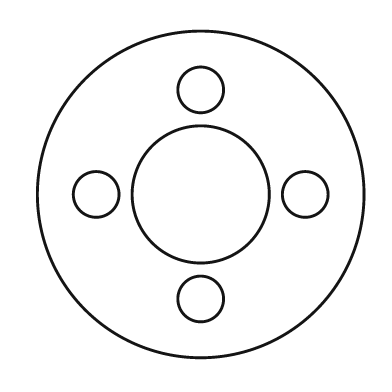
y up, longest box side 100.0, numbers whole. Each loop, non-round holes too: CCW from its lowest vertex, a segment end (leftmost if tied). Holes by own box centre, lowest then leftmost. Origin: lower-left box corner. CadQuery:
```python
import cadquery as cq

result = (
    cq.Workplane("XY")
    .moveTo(50.0, 50.0)
    .circle(50.0)
    .moveTo(50.0, 18.0)
    .circle(7.0)
    .moveTo(18.0, 50.0)
    .circle(7.0)
    .moveTo(50.0, 50.0)
    .circle(21.0)
    .moveTo(82.0, 50.0)
    .circle(7.0)
    .moveTo(50.0, 82.0)
    .circle(7.0)
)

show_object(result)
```